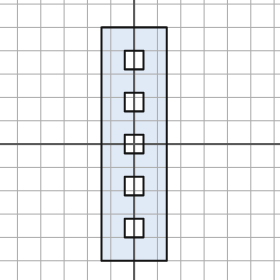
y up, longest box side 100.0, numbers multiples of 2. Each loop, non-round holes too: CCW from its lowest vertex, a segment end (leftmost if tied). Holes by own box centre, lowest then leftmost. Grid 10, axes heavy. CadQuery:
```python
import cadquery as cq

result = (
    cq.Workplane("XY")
    .moveTo(-14.0, -50.0)
    .lineTo(14.0, -50.0)
    .lineTo(14.0, 50.0)
    .lineTo(-14.0, 50.0)
    .close()
    .moveTo(-4.0, -40.0)
    .lineTo(4.0, -40.0)
    .lineTo(4.0, -32.0)
    .lineTo(-4.0, -32.0)
    .close()
    .moveTo(-4.0, -22.0)
    .lineTo(4.0, -22.0)
    .lineTo(4.0, -14.0)
    .lineTo(-4.0, -14.0)
    .close()
    .moveTo(-4.0, -4.0)
    .lineTo(4.0, -4.0)
    .lineTo(4.0, 4.0)
    .lineTo(-4.0, 4.0)
    .close()
    .moveTo(-4.0, 14.0)
    .lineTo(4.0, 14.0)
    .lineTo(4.0, 22.0)
    .lineTo(-4.0, 22.0)
    .close()
    .moveTo(-4.0, 32.0)
    .lineTo(4.0, 32.0)
    .lineTo(4.0, 40.0)
    .lineTo(-4.0, 40.0)
    .close()
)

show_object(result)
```